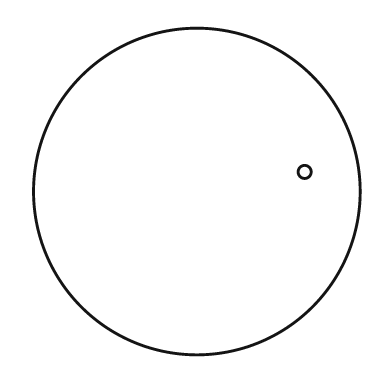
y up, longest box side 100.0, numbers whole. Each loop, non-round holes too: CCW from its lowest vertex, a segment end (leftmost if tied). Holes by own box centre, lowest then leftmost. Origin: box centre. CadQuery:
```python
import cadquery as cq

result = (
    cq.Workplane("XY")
    .moveTo(0.0, 0.0)
    .circle(50.0)
    .moveTo(33.0, 6.0)
    .circle(2.0)
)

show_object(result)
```